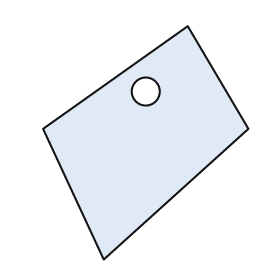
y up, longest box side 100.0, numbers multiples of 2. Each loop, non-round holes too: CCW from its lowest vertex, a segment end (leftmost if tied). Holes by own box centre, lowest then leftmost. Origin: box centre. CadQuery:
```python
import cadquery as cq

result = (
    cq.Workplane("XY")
    .moveTo(-18.0, -50.0)
    .lineTo(44.0, 6.0)
    .lineTo(18.0, 50.0)
    .lineTo(-44.0, 6.0)
    .close()
    .moveTo(0.0, 22.0)
    .circle(6.0)
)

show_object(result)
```